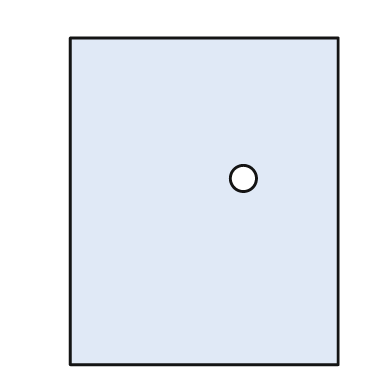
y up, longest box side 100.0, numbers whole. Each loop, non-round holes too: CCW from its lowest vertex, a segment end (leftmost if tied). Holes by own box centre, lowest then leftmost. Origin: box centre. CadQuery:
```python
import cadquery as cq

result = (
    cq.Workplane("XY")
    .moveTo(-41.0, -50.0)
    .lineTo(41.0, -50.0)
    .lineTo(41.0, 50.0)
    .lineTo(-41.0, 50.0)
    .close()
    .moveTo(12.0, 7.0)
    .circle(4.0)
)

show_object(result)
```